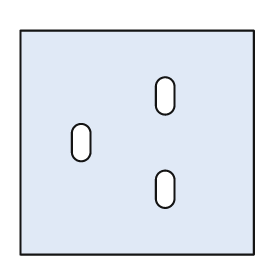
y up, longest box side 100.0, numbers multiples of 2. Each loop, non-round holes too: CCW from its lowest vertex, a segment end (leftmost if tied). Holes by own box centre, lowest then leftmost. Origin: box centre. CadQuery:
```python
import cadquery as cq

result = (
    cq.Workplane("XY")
    .moveTo(-50.0, -48.0)
    .lineTo(50.0, -48.0)
    .lineTo(50.0, 48.0)
    .lineTo(-50.0, 48.0)
    .close()
    .moveTo(8.0, -24.0)
    .threePointArc((12.0, -28.0), (16.0, -24.0))
    .lineTo(16.0, -16.0)
    .threePointArc((12.0, -12.0), (8.0, -16.0))
    .close()
    .moveTo(-28.0, -4.0)
    .threePointArc((-24.0, -8.0), (-20.0, -4.0))
    .lineTo(-20.0, 4.0)
    .threePointArc((-24.0, 8.0), (-28.0, 4.0))
    .close()
    .moveTo(8.0, 16.0)
    .threePointArc((12.0, 12.0), (16.0, 16.0))
    .lineTo(16.0, 24.0)
    .threePointArc((12.0, 28.0), (8.0, 24.0))
    .close()
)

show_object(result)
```